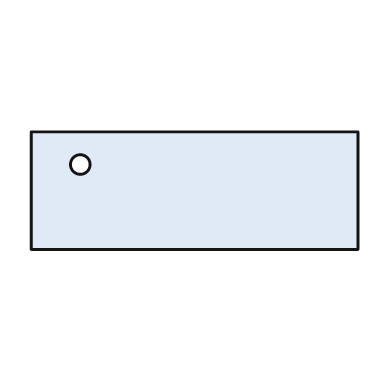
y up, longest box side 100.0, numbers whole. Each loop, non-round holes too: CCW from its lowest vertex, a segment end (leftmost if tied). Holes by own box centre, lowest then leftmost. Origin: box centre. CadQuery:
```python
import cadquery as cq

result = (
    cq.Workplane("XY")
    .moveTo(-50.0, -18.0)
    .lineTo(50.0, -18.0)
    .lineTo(50.0, 18.0)
    .lineTo(-50.0, 18.0)
    .close()
    .moveTo(-35.0, 8.0)
    .circle(3.0)
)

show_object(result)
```